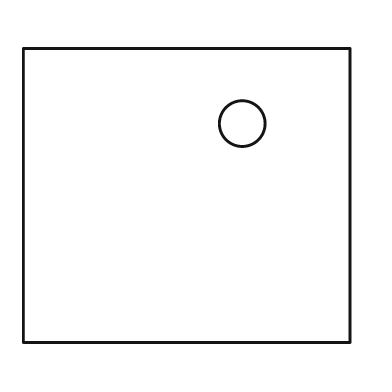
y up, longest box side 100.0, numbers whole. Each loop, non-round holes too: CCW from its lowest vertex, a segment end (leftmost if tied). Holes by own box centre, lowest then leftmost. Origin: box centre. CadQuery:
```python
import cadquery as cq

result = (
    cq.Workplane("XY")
    .moveTo(-50.0, -45.0)
    .lineTo(50.0, -45.0)
    .lineTo(50.0, 45.0)
    .lineTo(-50.0, 45.0)
    .close()
    .moveTo(17.0, 22.0)
    .circle(7.0)
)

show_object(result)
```